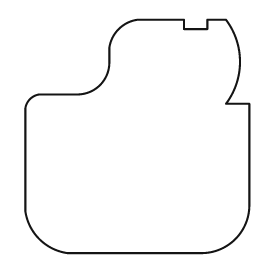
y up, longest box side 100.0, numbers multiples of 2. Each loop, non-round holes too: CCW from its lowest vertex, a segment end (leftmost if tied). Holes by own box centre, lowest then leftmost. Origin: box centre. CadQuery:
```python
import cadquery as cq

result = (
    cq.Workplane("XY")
    .moveTo(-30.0, -50.0)
    .lineTo(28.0, -50.0)
    .threePointArc((42.0, -44.0), (48.0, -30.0))
    .lineTo(48.0, 14.0)
    .lineTo(38.0, 14.0)
    .threePointArc((44.0, 32.0), (38.0, 50.0))
    .lineTo(30.0, 50.0)
    .lineTo(30.0, 46.0)
    .lineTo(20.0, 46.0)
    .lineTo(20.0, 50.0)
    .lineTo(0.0, 50.0)
    .threePointArc((-8.0, 46.0), (-12.0, 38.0))
    .lineTo(-12.0, 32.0)
    .threePointArc((-16.0, 22.0), (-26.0, 18.0))
    .lineTo(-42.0, 18.0)
    .threePointArc((-46.0, 16.0), (-48.0, 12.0))
    .lineTo(-48.0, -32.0)
    .threePointArc((-42.0, -44.0), (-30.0, -50.0))
    .close()
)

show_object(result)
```